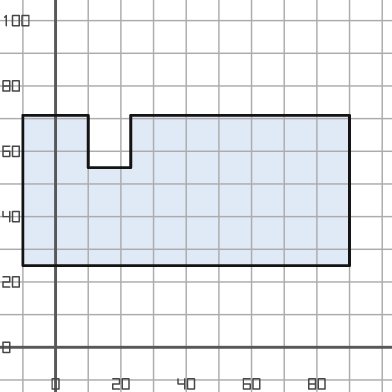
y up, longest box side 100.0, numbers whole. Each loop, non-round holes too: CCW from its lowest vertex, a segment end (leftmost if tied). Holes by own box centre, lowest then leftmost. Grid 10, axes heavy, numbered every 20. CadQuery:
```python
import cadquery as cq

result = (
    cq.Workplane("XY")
    .moveTo(-10.0, 25.0)
    .lineTo(90.0, 25.0)
    .lineTo(90.0, 71.0)
    .lineTo(23.0, 71.0)
    .lineTo(23.0, 55.0)
    .lineTo(10.0, 55.0)
    .lineTo(10.0, 71.0)
    .lineTo(-10.0, 71.0)
    .close()
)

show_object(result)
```